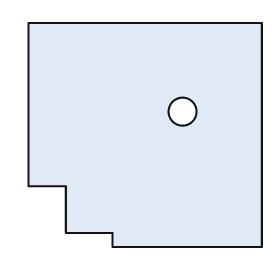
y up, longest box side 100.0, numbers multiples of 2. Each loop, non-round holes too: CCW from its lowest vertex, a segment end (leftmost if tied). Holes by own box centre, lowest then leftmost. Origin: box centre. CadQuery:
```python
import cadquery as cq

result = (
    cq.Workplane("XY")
    .moveTo(-14.0, -48.0)
    .lineTo(50.0, -48.0)
    .lineTo(50.0, 48.0)
    .lineTo(-50.0, 48.0)
    .lineTo(-50.0, -22.0)
    .lineTo(-34.0, -22.0)
    .lineTo(-34.0, -42.0)
    .lineTo(-14.0, -42.0)
    .close()
    .moveTo(16.0, 10.0)
    .circle(6.0)
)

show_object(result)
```